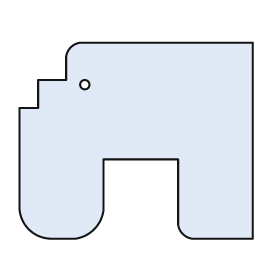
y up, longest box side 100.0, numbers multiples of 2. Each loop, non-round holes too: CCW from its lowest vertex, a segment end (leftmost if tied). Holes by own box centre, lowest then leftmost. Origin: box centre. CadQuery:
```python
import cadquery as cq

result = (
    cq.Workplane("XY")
    .moveTo(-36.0, -42.0)
    .lineTo(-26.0, -42.0)
    .threePointArc((-18.0, -38.0), (-14.0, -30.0))
    .lineTo(-14.0, -8.0)
    .lineTo(18.0, -8.0)
    .lineTo(18.0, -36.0)
    .threePointArc((20.0, -40.0), (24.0, -42.0))
    .lineTo(50.0, -42.0)
    .lineTo(50.0, 42.0)
    .lineTo(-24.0, 42.0)
    .threePointArc((-28.0, 40.0), (-30.0, 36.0))
    .lineTo(-30.0, 26.0)
    .lineTo(-42.0, 26.0)
    .lineTo(-42.0, 14.0)
    .lineTo(-50.0, 14.0)
    .lineTo(-50.0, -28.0)
    .threePointArc((-46.0, -38.0), (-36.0, -42.0))
    .close()
    .moveTo(-22.0, 24.0)
    .circle(2.0)
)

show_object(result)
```